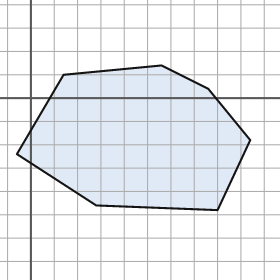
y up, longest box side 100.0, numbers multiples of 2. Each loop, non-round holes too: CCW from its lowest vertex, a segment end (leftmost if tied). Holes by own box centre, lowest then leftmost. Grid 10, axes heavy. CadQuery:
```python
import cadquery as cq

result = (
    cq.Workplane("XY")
    .moveTo(80.0, -48.0)
    .lineTo(94.0, -18.0)
    .lineTo(76.0, 4.0)
    .lineTo(56.0, 14.0)
    .lineTo(14.0, 10.0)
    .lineTo(-6.0, -24.0)
    .lineTo(28.0, -46.0)
    .close()
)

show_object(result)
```